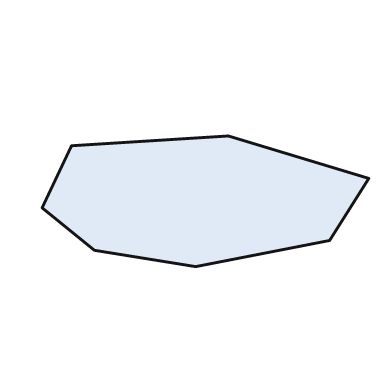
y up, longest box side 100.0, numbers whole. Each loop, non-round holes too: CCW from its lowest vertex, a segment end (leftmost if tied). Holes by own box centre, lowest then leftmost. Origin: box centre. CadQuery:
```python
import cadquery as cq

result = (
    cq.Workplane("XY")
    .moveTo(-3.0, -20.0)
    .lineTo(38.0, -12.0)
    .lineTo(50.0, 7.0)
    .lineTo(7.0, 20.0)
    .lineTo(-41.0, 17.0)
    .lineTo(-50.0, -2.0)
    .lineTo(-34.0, -15.0)
    .close()
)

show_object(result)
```